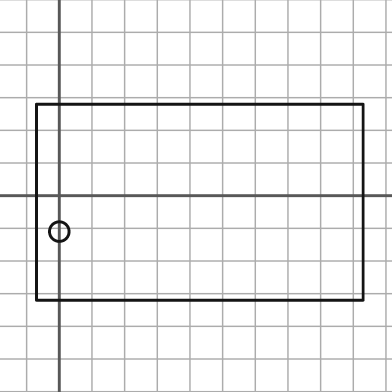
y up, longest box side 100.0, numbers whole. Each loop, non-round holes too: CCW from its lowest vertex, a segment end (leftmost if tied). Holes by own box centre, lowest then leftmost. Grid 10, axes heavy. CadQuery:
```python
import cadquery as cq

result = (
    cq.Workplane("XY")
    .moveTo(-7.0, -32.0)
    .lineTo(93.0, -32.0)
    .lineTo(93.0, 28.0)
    .lineTo(-7.0, 28.0)
    .close()
    .moveTo(0.0, -11.0)
    .circle(3.0)
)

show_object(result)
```